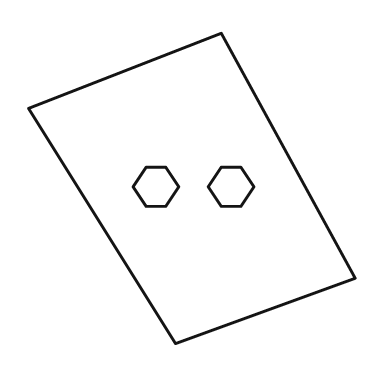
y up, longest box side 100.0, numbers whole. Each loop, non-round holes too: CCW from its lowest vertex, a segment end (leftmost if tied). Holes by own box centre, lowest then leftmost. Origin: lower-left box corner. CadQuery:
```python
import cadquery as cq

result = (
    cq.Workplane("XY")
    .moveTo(45.0, 0.0)
    .lineTo(100.0, 20.0)
    .lineTo(59.0, 95.0)
    .lineTo(0.0, 72.0)
    .close()
    .moveTo(36.0, 42.0)
    .lineTo(42.0, 42.0)
    .lineTo(46.0, 48.0)
    .lineTo(42.0, 54.0)
    .lineTo(36.0, 54.0)
    .lineTo(32.0, 48.0)
    .close()
    .moveTo(59.0, 42.0)
    .lineTo(65.0, 42.0)
    .lineTo(69.0, 48.0)
    .lineTo(65.0, 54.0)
    .lineTo(59.0, 54.0)
    .lineTo(55.0, 48.0)
    .close()
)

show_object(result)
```